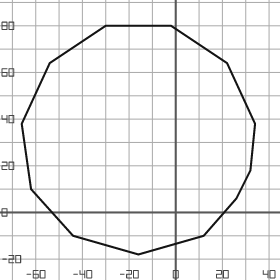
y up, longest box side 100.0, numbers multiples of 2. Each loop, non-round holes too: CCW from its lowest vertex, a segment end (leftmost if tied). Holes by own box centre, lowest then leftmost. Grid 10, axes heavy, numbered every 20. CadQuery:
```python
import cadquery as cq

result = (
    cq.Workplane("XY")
    .moveTo(-16.0, -18.0)
    .lineTo(12.0, -10.0)
    .lineTo(26.0, 6.0)
    .lineTo(32.0, 18.0)
    .lineTo(34.0, 38.0)
    .lineTo(22.0, 64.0)
    .lineTo(-2.0, 80.0)
    .lineTo(-30.0, 80.0)
    .lineTo(-54.0, 64.0)
    .lineTo(-66.0, 38.0)
    .lineTo(-62.0, 10.0)
    .lineTo(-44.0, -10.0)
    .close()
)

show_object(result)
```